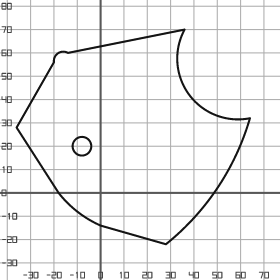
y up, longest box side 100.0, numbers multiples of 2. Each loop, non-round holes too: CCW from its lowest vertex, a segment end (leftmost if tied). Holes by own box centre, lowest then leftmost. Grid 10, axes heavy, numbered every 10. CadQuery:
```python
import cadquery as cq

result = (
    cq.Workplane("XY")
    .moveTo(28.0, -22.0)
    .threePointArc((50.0, 2.0), (64.0, 32.0))
    .threePointArc((38.0, 42.0), (36.0, 70.0))
    .lineTo(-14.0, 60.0)
    .threePointArc((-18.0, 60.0), (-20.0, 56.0))
    .lineTo(-36.0, 28.0)
    .lineTo(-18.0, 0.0)
    .threePointArc((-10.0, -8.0), (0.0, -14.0))
    .close()
    .moveTo(-8.0, 20.0)
    .circle(4.0)
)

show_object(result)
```